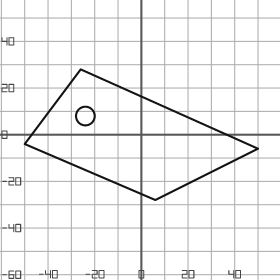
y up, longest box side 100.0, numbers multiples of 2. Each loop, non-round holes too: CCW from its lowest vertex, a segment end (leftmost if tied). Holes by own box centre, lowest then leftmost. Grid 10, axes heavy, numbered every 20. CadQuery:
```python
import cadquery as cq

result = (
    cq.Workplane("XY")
    .moveTo(6.0, -28.0)
    .lineTo(50.0, -6.0)
    .lineTo(-26.0, 28.0)
    .lineTo(-50.0, -4.0)
    .close()
    .moveTo(-24.0, 8.0)
    .circle(4.0)
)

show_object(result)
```